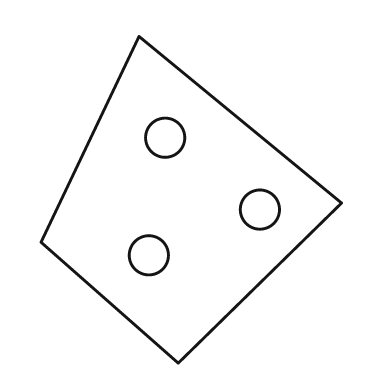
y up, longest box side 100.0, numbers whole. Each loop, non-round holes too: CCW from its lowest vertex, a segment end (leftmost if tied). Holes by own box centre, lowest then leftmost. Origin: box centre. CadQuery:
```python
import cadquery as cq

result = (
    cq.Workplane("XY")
    .moveTo(-4.0, -50.0)
    .lineTo(46.0, -1.0)
    .lineTo(-16.0, 50.0)
    .lineTo(-46.0, -13.0)
    .close()
    .moveTo(-13.0, -17.0)
    .circle(6.0)
    .moveTo(21.0, -3.0)
    .circle(6.0)
    .moveTo(-8.0, 19.0)
    .circle(6.0)
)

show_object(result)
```